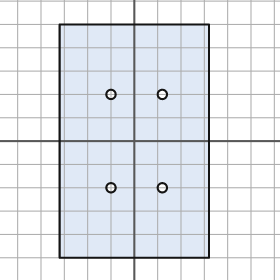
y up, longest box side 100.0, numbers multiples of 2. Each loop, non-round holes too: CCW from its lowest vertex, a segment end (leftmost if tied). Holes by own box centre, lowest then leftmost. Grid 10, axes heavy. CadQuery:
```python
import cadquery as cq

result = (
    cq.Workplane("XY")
    .moveTo(-32.0, -50.0)
    .lineTo(32.0, -50.0)
    .lineTo(32.0, 50.0)
    .lineTo(-32.0, 50.0)
    .close()
    .moveTo(-10.0, -20.0)
    .circle(2.0)
    .moveTo(12.0, -20.0)
    .circle(2.0)
    .moveTo(-10.0, 20.0)
    .circle(2.0)
    .moveTo(12.0, 20.0)
    .circle(2.0)
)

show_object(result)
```